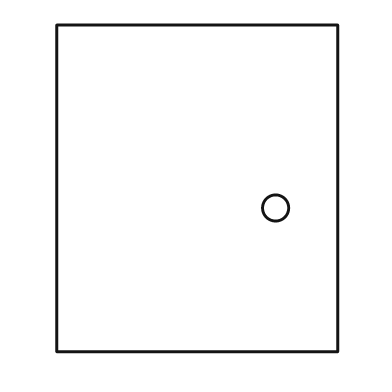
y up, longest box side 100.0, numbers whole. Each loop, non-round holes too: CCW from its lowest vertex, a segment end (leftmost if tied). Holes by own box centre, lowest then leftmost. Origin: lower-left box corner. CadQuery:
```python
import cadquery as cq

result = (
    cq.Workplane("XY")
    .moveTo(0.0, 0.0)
    .lineTo(86.0, 0.0)
    .lineTo(86.0, 100.0)
    .lineTo(0.0, 100.0)
    .close()
    .moveTo(67.0, 44.0)
    .circle(4.0)
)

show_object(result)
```